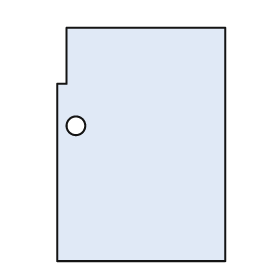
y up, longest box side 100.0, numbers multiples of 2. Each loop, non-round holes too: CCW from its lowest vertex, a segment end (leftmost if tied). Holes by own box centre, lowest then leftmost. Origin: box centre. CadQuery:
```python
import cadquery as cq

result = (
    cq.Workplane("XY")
    .moveTo(-36.0, -50.0)
    .lineTo(36.0, -50.0)
    .lineTo(36.0, 50.0)
    .lineTo(-32.0, 50.0)
    .lineTo(-32.0, 26.0)
    .lineTo(-36.0, 26.0)
    .close()
    .moveTo(-28.0, 8.0)
    .circle(4.0)
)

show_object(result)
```